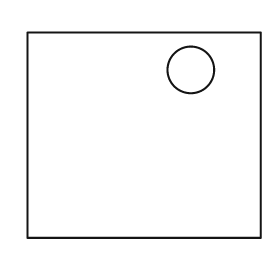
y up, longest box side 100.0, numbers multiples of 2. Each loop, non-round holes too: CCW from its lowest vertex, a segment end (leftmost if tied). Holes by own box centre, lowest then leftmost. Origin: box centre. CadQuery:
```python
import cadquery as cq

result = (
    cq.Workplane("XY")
    .moveTo(-50.0, -44.0)
    .lineTo(50.0, -44.0)
    .lineTo(50.0, 44.0)
    .lineTo(-50.0, 44.0)
    .close()
    .moveTo(20.0, 28.0)
    .circle(10.0)
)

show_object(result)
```